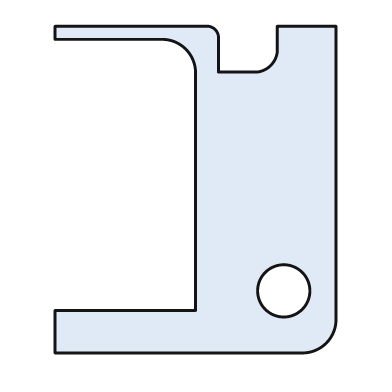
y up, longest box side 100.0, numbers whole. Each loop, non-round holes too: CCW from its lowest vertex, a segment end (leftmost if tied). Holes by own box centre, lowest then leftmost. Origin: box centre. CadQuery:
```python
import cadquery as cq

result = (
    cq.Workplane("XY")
    .moveTo(-43.0, -50.0)
    .lineTo(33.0, -50.0)
    .threePointArc((40.0, -47.0), (43.0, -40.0))
    .lineTo(43.0, 50.0)
    .lineTo(25.0, 50.0)
    .lineTo(25.0, 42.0)
    .threePointArc((23.0, 38.0), (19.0, 36.0))
    .lineTo(7.0, 36.0)
    .lineTo(7.0, 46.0)
    .threePointArc((6.0, 49.0), (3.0, 50.0))
    .lineTo(-43.0, 50.0)
    .lineTo(-43.0, 46.0)
    .lineTo(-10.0, 46.0)
    .threePointArc((-3.0, 43.0), (0.0, 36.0))
    .lineTo(0.0, -37.0)
    .lineTo(-43.0, -37.0)
    .close()
    .moveTo(27.0, -31.0)
    .circle(8.0)
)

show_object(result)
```